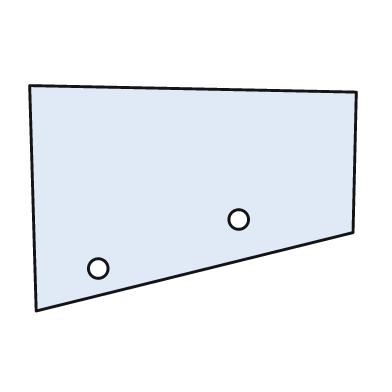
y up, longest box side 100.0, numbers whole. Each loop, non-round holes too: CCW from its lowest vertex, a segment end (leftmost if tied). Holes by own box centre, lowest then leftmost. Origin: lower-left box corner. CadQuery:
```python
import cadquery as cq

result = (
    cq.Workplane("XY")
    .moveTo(2.0, 0.0)
    .lineTo(99.0, 24.0)
    .lineTo(100.0, 67.0)
    .lineTo(0.0, 69.0)
    .close()
    .moveTo(21.0, 13.0)
    .circle(3.0)
    .moveTo(64.0, 28.0)
    .circle(3.0)
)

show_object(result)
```